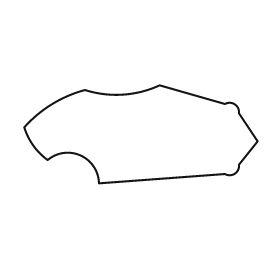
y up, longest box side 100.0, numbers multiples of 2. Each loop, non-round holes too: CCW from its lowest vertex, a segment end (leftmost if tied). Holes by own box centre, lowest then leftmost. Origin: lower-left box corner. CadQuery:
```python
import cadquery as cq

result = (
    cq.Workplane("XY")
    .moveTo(32.0, 0.0)
    .lineTo(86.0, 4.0)
    .threePointArc((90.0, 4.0), (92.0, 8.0))
    .lineTo(100.0, 18.0)
    .lineTo(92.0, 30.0)
    .threePointArc((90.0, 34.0), (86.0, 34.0))
    .lineTo(58.0, 42.0)
    .threePointArc((42.0, 38.0), (26.0, 40.0))
    .threePointArc((12.0, 34.0), (0.0, 24.0))
    .threePointArc((4.0, 16.0), (10.0, 10.0))
    .threePointArc((24.0, 12.0), (32.0, 0.0))
    .close()
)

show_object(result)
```